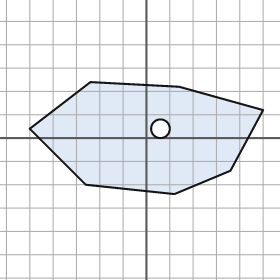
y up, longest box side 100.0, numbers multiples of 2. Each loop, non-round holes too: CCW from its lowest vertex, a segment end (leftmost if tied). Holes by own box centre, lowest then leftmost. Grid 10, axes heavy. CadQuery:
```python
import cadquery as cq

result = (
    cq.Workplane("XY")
    .moveTo(12.0, -24.0)
    .lineTo(36.0, -14.0)
    .lineTo(50.0, 12.0)
    .lineTo(14.0, 22.0)
    .lineTo(-24.0, 24.0)
    .lineTo(-50.0, 4.0)
    .lineTo(-26.0, -20.0)
    .close()
    .moveTo(6.0, 4.0)
    .circle(4.0)
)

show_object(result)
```